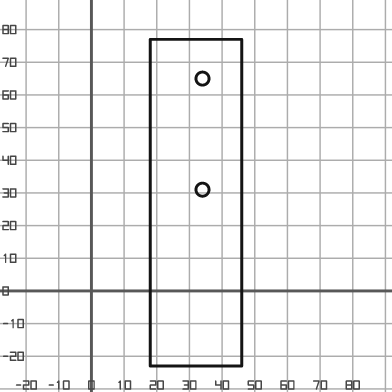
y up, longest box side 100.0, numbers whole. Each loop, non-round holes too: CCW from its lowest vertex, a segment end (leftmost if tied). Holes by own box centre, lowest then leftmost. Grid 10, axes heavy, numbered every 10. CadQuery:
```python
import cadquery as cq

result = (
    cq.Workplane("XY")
    .moveTo(18.0, -23.0)
    .lineTo(46.0, -23.0)
    .lineTo(46.0, 77.0)
    .lineTo(18.0, 77.0)
    .close()
    .moveTo(34.0, 31.0)
    .circle(2.0)
    .moveTo(34.0, 65.0)
    .circle(2.0)
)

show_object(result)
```